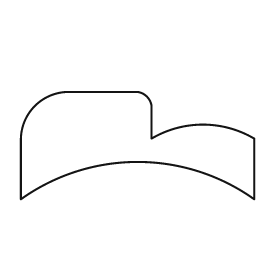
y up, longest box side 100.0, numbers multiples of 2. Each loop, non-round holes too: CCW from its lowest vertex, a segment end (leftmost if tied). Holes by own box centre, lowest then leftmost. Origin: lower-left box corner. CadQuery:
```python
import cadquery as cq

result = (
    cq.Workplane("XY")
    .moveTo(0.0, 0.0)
    .threePointArc((50.0, 16.0), (100.0, 0.0))
    .lineTo(100.0, 26.0)
    .threePointArc((78.0, 32.0), (56.0, 26.0))
    .lineTo(56.0, 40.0)
    .threePointArc((54.0, 44.0), (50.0, 46.0))
    .lineTo(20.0, 46.0)
    .threePointArc((6.0, 40.0), (0.0, 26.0))
    .close()
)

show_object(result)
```